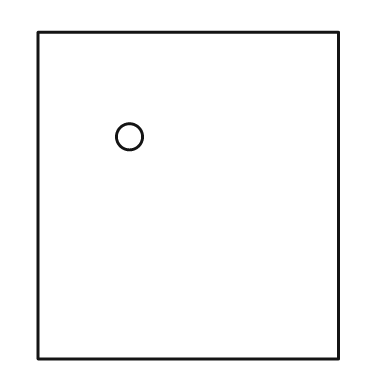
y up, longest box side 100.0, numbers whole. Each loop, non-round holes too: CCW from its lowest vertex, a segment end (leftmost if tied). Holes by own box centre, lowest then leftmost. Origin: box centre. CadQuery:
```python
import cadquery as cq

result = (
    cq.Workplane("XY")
    .moveTo(-46.0, -50.0)
    .lineTo(46.0, -50.0)
    .lineTo(46.0, 50.0)
    .lineTo(-46.0, 50.0)
    .close()
    .moveTo(-18.0, 18.0)
    .circle(4.0)
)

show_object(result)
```